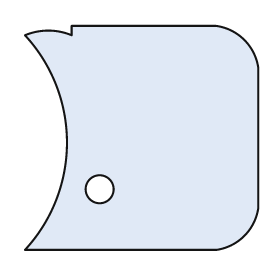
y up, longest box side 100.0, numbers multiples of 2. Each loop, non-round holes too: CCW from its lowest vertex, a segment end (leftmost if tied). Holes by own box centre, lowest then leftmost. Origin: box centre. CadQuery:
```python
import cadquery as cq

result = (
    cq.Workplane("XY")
    .moveTo(-50.0, -48.0)
    .lineTo(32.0, -48.0)
    .threePointArc((44.0, -42.0), (50.0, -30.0))
    .lineTo(50.0, 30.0)
    .threePointArc((44.0, 42.0), (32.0, 48.0))
    .lineTo(-30.0, 48.0)
    .lineTo(-30.0, 44.0)
    .threePointArc((-40.0, 46.0), (-50.0, 44.0))
    .threePointArc((-32.0, -2.0), (-50.0, -48.0))
    .close()
    .moveTo(-18.0, -22.0)
    .circle(6.0)
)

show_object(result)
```